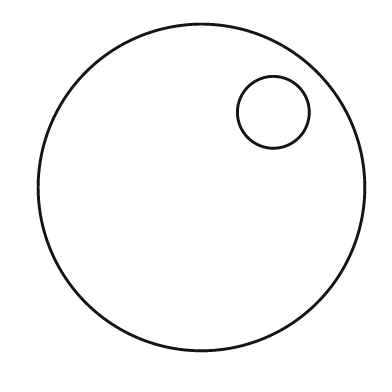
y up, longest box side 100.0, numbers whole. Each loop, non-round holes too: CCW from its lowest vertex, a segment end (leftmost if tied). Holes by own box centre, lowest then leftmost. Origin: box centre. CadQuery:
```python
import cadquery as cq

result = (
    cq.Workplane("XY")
    .moveTo(0.0, 0.0)
    .circle(50.0)
    .moveTo(22.0, 23.0)
    .circle(11.0)
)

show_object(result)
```